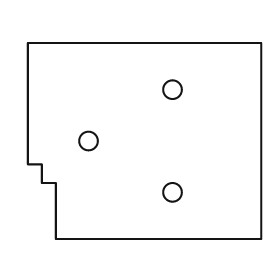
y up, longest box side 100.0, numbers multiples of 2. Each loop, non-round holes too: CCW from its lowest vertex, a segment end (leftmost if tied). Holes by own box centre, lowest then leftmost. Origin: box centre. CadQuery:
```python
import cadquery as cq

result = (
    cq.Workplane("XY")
    .moveTo(-38.0, -42.0)
    .lineTo(50.0, -42.0)
    .lineTo(50.0, 42.0)
    .lineTo(-50.0, 42.0)
    .lineTo(-50.0, -10.0)
    .lineTo(-44.0, -10.0)
    .lineTo(-44.0, -18.0)
    .lineTo(-38.0, -18.0)
    .close()
    .moveTo(12.0, -22.0)
    .circle(4.0)
    .moveTo(-24.0, 0.0)
    .circle(4.0)
    .moveTo(12.0, 22.0)
    .circle(4.0)
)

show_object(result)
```